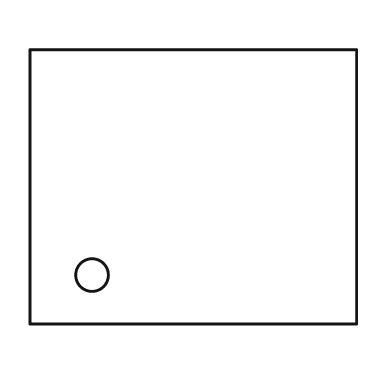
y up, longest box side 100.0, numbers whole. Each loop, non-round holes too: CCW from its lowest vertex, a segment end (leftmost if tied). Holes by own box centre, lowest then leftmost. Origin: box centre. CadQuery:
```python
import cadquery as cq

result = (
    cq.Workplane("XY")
    .moveTo(-50.0, -42.0)
    .lineTo(50.0, -42.0)
    .lineTo(50.0, 42.0)
    .lineTo(-50.0, 42.0)
    .close()
    .moveTo(-31.0, -27.0)
    .circle(5.0)
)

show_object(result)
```